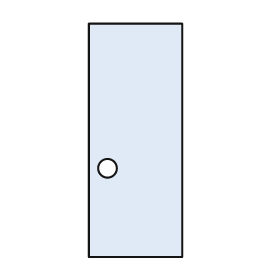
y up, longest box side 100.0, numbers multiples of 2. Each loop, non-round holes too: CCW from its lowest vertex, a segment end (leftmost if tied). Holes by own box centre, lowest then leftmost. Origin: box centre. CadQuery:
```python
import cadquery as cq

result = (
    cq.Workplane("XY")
    .moveTo(-20.0, -50.0)
    .lineTo(20.0, -50.0)
    .lineTo(20.0, 50.0)
    .lineTo(-20.0, 50.0)
    .close()
    .moveTo(-12.0, -12.0)
    .circle(4.0)
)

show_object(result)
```